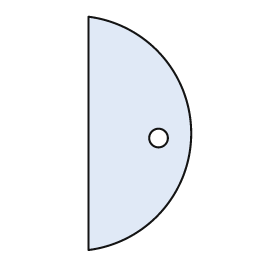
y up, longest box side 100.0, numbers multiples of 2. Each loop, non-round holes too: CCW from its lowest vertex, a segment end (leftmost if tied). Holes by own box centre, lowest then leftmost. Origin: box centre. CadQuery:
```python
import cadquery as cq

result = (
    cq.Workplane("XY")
    .moveTo(-22.0, -50.0)
    .threePointArc((22.0, 0.0), (-22.0, 50.0))
    .close()
    .moveTo(8.0, -2.0)
    .circle(4.0)
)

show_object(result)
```